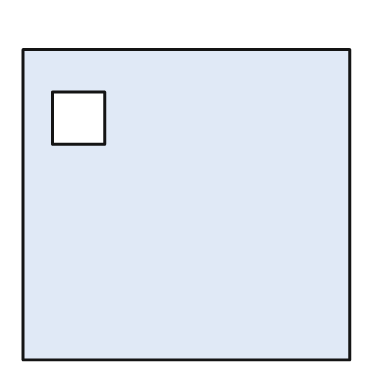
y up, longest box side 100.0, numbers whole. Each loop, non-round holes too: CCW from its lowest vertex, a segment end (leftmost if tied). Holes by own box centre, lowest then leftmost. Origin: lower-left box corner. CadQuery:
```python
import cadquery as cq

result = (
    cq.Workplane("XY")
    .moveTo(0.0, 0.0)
    .lineTo(100.0, 0.0)
    .lineTo(100.0, 95.0)
    .lineTo(0.0, 95.0)
    .close()
    .moveTo(9.0, 66.0)
    .lineTo(25.0, 66.0)
    .lineTo(25.0, 82.0)
    .lineTo(9.0, 82.0)
    .close()
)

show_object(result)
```